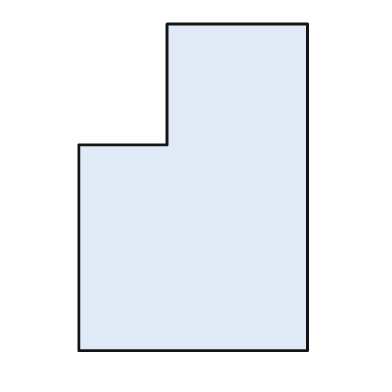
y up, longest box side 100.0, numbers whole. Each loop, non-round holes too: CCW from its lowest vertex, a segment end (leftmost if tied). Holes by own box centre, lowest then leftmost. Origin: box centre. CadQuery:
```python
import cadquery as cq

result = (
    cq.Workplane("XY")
    .moveTo(-35.0, -50.0)
    .lineTo(35.0, -50.0)
    .lineTo(35.0, 50.0)
    .lineTo(-8.0, 50.0)
    .lineTo(-8.0, 13.0)
    .lineTo(-35.0, 13.0)
    .close()
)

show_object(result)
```